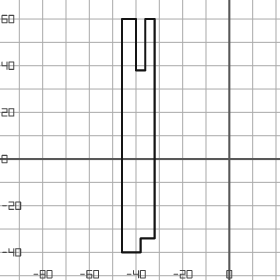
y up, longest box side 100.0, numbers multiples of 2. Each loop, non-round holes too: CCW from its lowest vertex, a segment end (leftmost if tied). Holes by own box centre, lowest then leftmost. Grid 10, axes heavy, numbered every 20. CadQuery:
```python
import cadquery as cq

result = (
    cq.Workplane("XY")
    .moveTo(-46.0, -40.0)
    .lineTo(-38.0, -40.0)
    .lineTo(-38.0, -34.0)
    .lineTo(-32.0, -34.0)
    .lineTo(-32.0, 60.0)
    .lineTo(-36.0, 60.0)
    .lineTo(-36.0, 38.0)
    .lineTo(-40.0, 38.0)
    .lineTo(-40.0, 60.0)
    .lineTo(-46.0, 60.0)
    .close()
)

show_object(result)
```